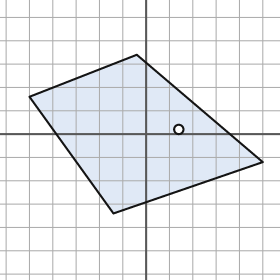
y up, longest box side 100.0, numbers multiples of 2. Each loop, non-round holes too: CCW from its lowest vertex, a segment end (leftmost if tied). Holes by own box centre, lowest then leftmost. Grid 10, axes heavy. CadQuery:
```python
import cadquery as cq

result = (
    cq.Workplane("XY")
    .moveTo(-14.0, -34.0)
    .lineTo(50.0, -12.0)
    .lineTo(-4.0, 34.0)
    .lineTo(-50.0, 16.0)
    .close()
    .moveTo(14.0, 2.0)
    .circle(2.0)
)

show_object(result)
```